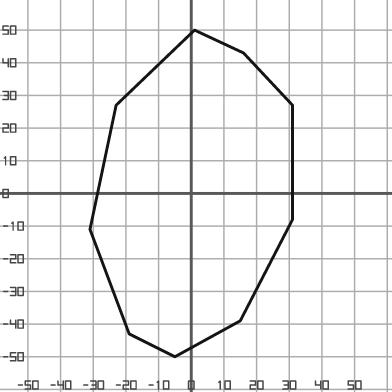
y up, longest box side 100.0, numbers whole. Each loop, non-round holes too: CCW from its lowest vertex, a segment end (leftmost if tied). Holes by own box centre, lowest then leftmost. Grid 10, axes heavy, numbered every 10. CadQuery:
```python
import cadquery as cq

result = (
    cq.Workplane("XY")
    .moveTo(-5.0, -50.0)
    .lineTo(15.0, -39.0)
    .lineTo(31.0, -8.0)
    .lineTo(31.0, 27.0)
    .lineTo(16.0, 43.0)
    .lineTo(1.0, 50.0)
    .lineTo(-23.0, 27.0)
    .lineTo(-31.0, -11.0)
    .lineTo(-19.0, -43.0)
    .close()
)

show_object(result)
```